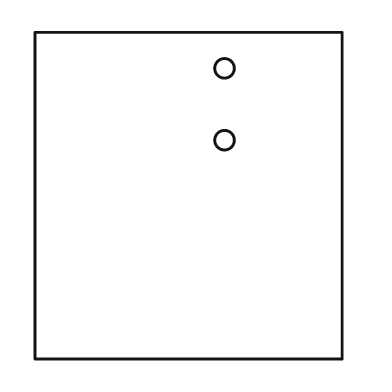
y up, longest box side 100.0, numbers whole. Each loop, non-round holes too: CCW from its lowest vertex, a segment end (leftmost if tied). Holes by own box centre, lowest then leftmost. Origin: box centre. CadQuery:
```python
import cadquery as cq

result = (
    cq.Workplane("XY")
    .moveTo(-47.0, -50.0)
    .lineTo(47.0, -50.0)
    .lineTo(47.0, 50.0)
    .lineTo(-47.0, 50.0)
    .close()
    .moveTo(11.0, 17.0)
    .circle(3.0)
    .moveTo(11.0, 39.0)
    .circle(3.0)
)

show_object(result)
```